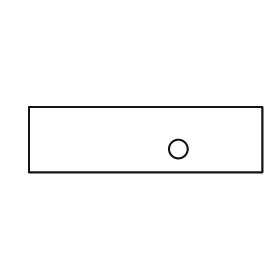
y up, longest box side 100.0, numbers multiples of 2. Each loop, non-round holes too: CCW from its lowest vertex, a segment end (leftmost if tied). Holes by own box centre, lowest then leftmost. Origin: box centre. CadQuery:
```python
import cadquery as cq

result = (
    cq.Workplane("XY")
    .moveTo(-50.0, -14.0)
    .lineTo(50.0, -14.0)
    .lineTo(50.0, 14.0)
    .lineTo(-50.0, 14.0)
    .close()
    .moveTo(14.0, -4.0)
    .circle(4.0)
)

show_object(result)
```